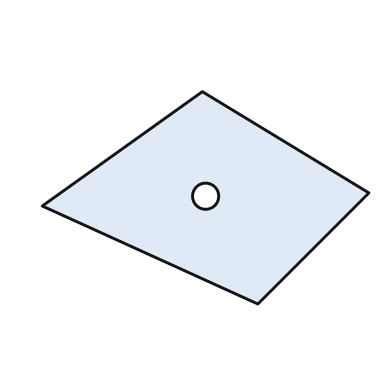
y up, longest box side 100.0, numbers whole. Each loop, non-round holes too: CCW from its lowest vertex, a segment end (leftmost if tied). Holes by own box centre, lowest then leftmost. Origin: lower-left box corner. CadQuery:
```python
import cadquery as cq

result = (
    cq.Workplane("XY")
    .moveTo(66.0, 0.0)
    .lineTo(100.0, 34.0)
    .lineTo(49.0, 65.0)
    .lineTo(0.0, 30.0)
    .close()
    .moveTo(50.0, 33.0)
    .circle(4.0)
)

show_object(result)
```